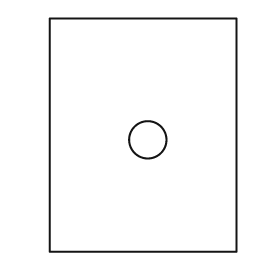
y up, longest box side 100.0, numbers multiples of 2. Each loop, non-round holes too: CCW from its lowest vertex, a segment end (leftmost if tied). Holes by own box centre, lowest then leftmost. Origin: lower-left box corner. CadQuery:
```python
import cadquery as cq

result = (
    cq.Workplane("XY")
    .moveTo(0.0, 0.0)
    .lineTo(80.0, 0.0)
    .lineTo(80.0, 100.0)
    .lineTo(0.0, 100.0)
    .close()
    .moveTo(42.0, 48.0)
    .circle(8.0)
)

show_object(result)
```